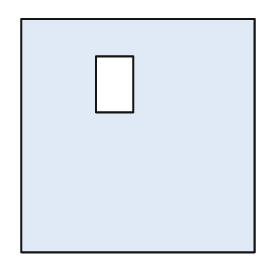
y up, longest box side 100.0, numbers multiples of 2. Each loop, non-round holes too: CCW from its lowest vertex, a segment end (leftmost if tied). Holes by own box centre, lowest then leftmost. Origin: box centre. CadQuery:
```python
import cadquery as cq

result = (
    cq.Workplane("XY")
    .moveTo(-50.0, -50.0)
    .lineTo(50.0, -50.0)
    .lineTo(50.0, 50.0)
    .lineTo(-50.0, 50.0)
    .close()
    .moveTo(-18.0, 10.0)
    .lineTo(-2.0, 10.0)
    .lineTo(-2.0, 34.0)
    .lineTo(-18.0, 34.0)
    .close()
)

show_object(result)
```